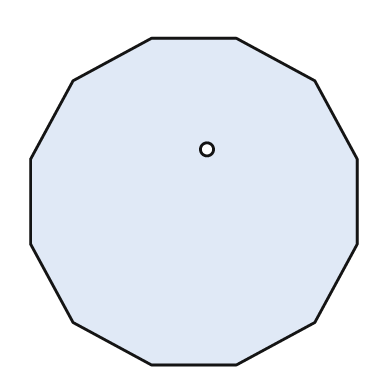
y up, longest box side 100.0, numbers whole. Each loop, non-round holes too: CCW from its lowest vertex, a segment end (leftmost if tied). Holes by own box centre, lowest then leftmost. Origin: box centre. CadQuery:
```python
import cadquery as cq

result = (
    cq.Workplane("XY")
    .moveTo(-13.0, -50.0)
    .lineTo(13.0, -50.0)
    .lineTo(37.0, -37.0)
    .lineTo(50.0, -13.0)
    .lineTo(50.0, 13.0)
    .lineTo(37.0, 37.0)
    .lineTo(13.0, 50.0)
    .lineTo(-13.0, 50.0)
    .lineTo(-37.0, 37.0)
    .lineTo(-50.0, 13.0)
    .lineTo(-50.0, -13.0)
    .lineTo(-37.0, -37.0)
    .close()
    .moveTo(4.0, 16.0)
    .circle(2.0)
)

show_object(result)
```